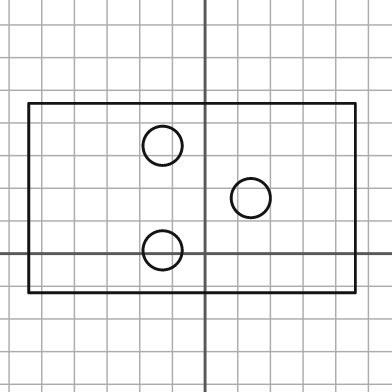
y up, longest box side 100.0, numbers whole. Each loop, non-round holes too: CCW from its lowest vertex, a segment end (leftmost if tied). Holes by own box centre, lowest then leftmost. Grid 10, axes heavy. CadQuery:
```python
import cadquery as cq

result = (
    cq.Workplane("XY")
    .moveTo(-54.0, -12.0)
    .lineTo(46.0, -12.0)
    .lineTo(46.0, 46.0)
    .lineTo(-54.0, 46.0)
    .close()
    .moveTo(-13.0, 1.0)
    .circle(6.0)
    .moveTo(14.0, 17.0)
    .circle(6.0)
    .moveTo(-13.0, 33.0)
    .circle(6.0)
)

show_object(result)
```